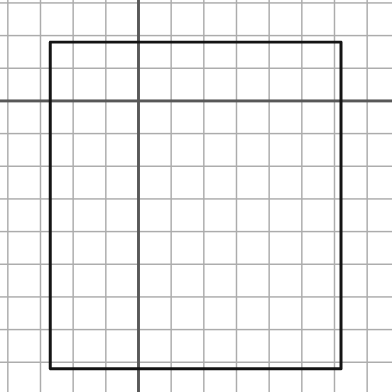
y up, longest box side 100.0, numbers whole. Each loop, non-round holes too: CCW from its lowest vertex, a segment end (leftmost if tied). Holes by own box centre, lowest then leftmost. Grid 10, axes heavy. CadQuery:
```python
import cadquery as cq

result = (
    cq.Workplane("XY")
    .moveTo(-27.0, -82.0)
    .lineTo(62.0, -82.0)
    .lineTo(62.0, 18.0)
    .lineTo(-27.0, 18.0)
    .close()
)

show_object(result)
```